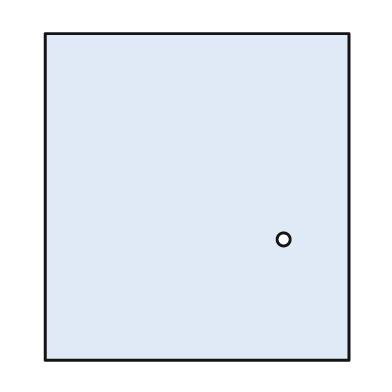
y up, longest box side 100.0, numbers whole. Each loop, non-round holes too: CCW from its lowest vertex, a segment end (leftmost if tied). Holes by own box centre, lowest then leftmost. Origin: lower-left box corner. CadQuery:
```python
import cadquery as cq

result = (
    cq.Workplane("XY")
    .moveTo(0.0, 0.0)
    .lineTo(93.0, 0.0)
    .lineTo(93.0, 100.0)
    .lineTo(0.0, 100.0)
    .close()
    .moveTo(73.0, 37.0)
    .circle(2.0)
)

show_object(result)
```